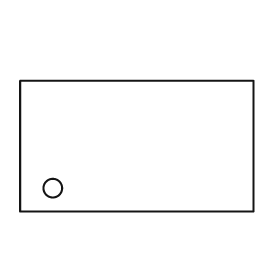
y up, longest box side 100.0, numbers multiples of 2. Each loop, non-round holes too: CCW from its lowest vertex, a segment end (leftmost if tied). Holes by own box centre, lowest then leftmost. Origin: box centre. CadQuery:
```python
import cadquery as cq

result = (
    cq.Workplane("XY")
    .moveTo(-50.0, -28.0)
    .lineTo(50.0, -28.0)
    .lineTo(50.0, 28.0)
    .lineTo(-50.0, 28.0)
    .close()
    .moveTo(-36.0, -18.0)
    .circle(4.0)
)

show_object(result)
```